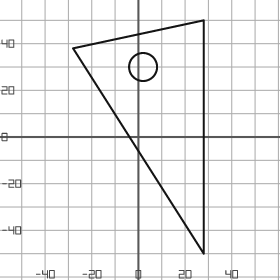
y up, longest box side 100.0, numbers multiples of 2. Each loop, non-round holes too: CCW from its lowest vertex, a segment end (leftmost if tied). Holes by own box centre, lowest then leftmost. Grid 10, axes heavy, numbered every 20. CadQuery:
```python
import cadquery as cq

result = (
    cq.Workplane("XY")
    .moveTo(28.0, -50.0)
    .lineTo(28.0, 50.0)
    .lineTo(-28.0, 38.0)
    .close()
    .moveTo(2.0, 30.0)
    .circle(6.0)
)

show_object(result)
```